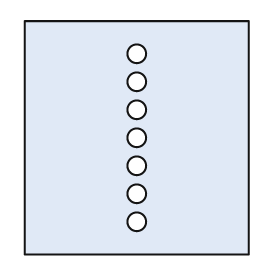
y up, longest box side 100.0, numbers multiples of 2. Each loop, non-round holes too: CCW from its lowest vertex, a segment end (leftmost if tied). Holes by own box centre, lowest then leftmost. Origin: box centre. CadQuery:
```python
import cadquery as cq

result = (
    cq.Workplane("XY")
    .moveTo(-48.0, -50.0)
    .lineTo(48.0, -50.0)
    .lineTo(48.0, 50.0)
    .lineTo(-48.0, 50.0)
    .close()
    .moveTo(0.0, -36.0)
    .circle(4.0)
    .moveTo(0.0, -24.0)
    .circle(4.0)
    .moveTo(0.0, -12.0)
    .circle(4.0)
    .moveTo(0.0, 0.0)
    .circle(4.0)
    .moveTo(0.0, 12.0)
    .circle(4.0)
    .moveTo(0.0, 24.0)
    .circle(4.0)
    .moveTo(0.0, 36.0)
    .circle(4.0)
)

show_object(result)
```